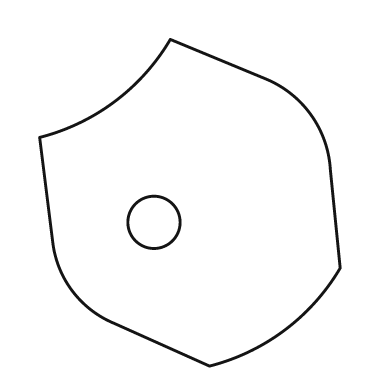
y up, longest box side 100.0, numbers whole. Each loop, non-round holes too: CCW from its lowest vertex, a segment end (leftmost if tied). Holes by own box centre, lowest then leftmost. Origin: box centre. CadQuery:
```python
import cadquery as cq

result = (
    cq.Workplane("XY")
    .moveTo(6.0, -50.0)
    .threePointArc((29.0, -39.0), (46.0, -20.0))
    .lineTo(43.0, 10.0)
    .threePointArc((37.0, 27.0), (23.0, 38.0))
    .lineTo(-6.0, 50.0)
    .threePointArc((-23.0, 31.0), (-46.0, 20.0))
    .lineTo(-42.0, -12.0)
    .threePointArc((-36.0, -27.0), (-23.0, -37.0))
    .close()
    .moveTo(-11.0, -6.0)
    .circle(8.0)
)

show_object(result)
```